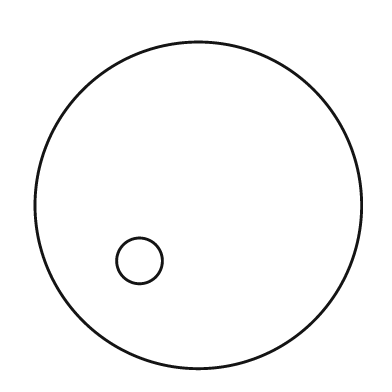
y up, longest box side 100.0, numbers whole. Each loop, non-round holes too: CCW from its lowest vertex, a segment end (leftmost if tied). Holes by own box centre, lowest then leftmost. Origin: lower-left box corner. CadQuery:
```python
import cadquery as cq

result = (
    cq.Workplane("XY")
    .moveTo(50.0, 50.0)
    .circle(50.0)
    .moveTo(32.0, 33.0)
    .circle(7.0)
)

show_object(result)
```